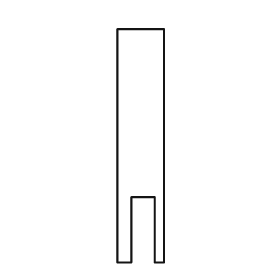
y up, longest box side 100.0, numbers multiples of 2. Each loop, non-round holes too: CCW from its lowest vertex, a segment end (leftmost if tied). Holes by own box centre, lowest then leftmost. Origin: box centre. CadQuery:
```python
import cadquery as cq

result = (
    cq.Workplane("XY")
    .moveTo(-10.0, -50.0)
    .lineTo(-4.0, -50.0)
    .lineTo(-4.0, -22.0)
    .lineTo(6.0, -22.0)
    .lineTo(6.0, -50.0)
    .lineTo(10.0, -50.0)
    .lineTo(10.0, 50.0)
    .lineTo(-10.0, 50.0)
    .close()
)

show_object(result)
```